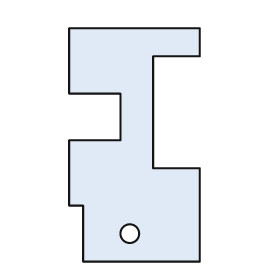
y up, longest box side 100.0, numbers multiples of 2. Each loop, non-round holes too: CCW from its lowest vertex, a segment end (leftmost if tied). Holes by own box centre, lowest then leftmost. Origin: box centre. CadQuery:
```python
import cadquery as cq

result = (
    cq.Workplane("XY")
    .moveTo(-22.0, -50.0)
    .lineTo(28.0, -50.0)
    .lineTo(28.0, -10.0)
    .lineTo(8.0, -10.0)
    .lineTo(8.0, 38.0)
    .lineTo(28.0, 38.0)
    .lineTo(28.0, 50.0)
    .lineTo(-28.0, 50.0)
    .lineTo(-28.0, 22.0)
    .lineTo(-6.0, 22.0)
    .lineTo(-6.0, 2.0)
    .lineTo(-28.0, 2.0)
    .lineTo(-28.0, -26.0)
    .lineTo(-22.0, -26.0)
    .close()
    .moveTo(-2.0, -38.0)
    .circle(4.0)
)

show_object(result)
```